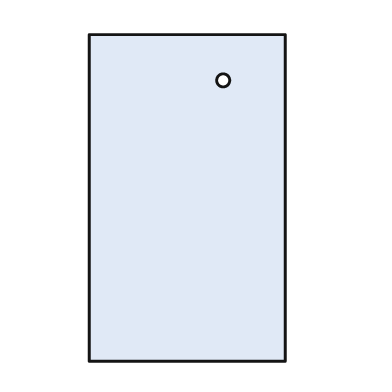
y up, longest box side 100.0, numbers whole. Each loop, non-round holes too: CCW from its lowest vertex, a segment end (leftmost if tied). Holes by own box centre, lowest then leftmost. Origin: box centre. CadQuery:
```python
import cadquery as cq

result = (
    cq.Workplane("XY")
    .moveTo(-30.0, -50.0)
    .lineTo(30.0, -50.0)
    .lineTo(30.0, 50.0)
    .lineTo(-30.0, 50.0)
    .close()
    .moveTo(11.0, 36.0)
    .circle(2.0)
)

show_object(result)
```